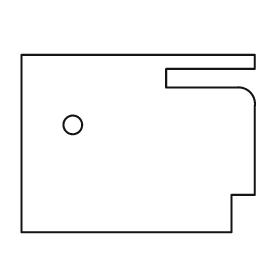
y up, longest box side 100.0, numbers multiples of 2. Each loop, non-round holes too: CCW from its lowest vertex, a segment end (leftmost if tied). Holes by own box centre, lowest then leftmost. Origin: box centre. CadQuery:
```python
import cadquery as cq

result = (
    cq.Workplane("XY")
    .moveTo(-50.0, -38.0)
    .lineTo(40.0, -38.0)
    .lineTo(40.0, -22.0)
    .lineTo(50.0, -22.0)
    .lineTo(50.0, 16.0)
    .threePointArc((48.0, 22.0), (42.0, 24.0))
    .lineTo(12.0, 24.0)
    .lineTo(12.0, 32.0)
    .lineTo(50.0, 32.0)
    .lineTo(50.0, 38.0)
    .lineTo(-50.0, 38.0)
    .close()
    .moveTo(-28.0, 8.0)
    .circle(4.0)
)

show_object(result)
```